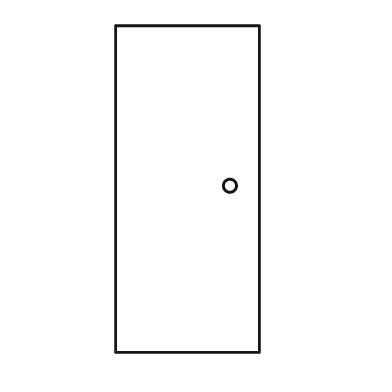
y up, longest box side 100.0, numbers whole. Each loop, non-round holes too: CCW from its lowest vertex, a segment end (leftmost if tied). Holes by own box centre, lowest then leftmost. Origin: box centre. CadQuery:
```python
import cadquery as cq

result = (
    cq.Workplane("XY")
    .moveTo(-22.0, -50.0)
    .lineTo(22.0, -50.0)
    .lineTo(22.0, 50.0)
    .lineTo(-22.0, 50.0)
    .close()
    .moveTo(13.0, 1.0)
    .circle(2.0)
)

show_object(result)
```